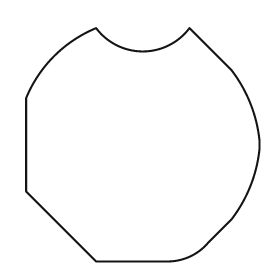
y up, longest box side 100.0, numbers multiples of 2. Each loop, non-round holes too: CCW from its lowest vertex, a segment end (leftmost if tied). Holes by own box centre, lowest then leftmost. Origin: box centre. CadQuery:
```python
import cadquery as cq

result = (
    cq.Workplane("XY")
    .moveTo(-20.0, -50.0)
    .lineTo(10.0, -50.0)
    .threePointArc((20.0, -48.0), (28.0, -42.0))
    .lineTo(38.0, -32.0)
    .threePointArc((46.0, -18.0), (50.0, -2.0))
    .lineTo(50.0, 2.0)
    .threePointArc((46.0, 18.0), (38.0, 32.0))
    .lineTo(20.0, 50.0)
    .threePointArc((0.0, 40.0), (-20.0, 50.0))
    .threePointArc((-38.0, 38.0), (-50.0, 20.0))
    .lineTo(-50.0, -20.0)
    .close()
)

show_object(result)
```